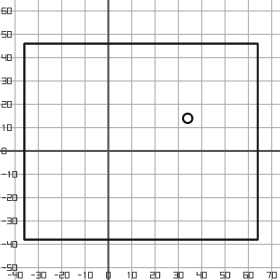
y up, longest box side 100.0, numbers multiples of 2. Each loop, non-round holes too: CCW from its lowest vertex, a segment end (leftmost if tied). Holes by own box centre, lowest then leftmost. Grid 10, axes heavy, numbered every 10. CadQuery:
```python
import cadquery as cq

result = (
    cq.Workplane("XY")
    .moveTo(-36.0, -38.0)
    .lineTo(64.0, -38.0)
    .lineTo(64.0, 46.0)
    .lineTo(-36.0, 46.0)
    .close()
    .moveTo(34.0, 14.0)
    .circle(2.0)
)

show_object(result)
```